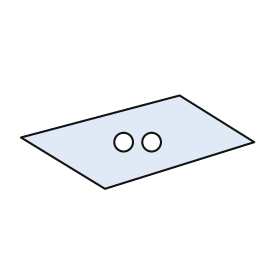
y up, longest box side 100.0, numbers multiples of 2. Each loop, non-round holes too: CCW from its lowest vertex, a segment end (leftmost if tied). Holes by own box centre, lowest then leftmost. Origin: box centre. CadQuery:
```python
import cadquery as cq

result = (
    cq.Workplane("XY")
    .moveTo(-14.0, -20.0)
    .lineTo(50.0, 0.0)
    .lineTo(18.0, 20.0)
    .lineTo(-50.0, 2.0)
    .close()
    .moveTo(-6.0, 0.0)
    .circle(4.0)
    .moveTo(6.0, 0.0)
    .circle(4.0)
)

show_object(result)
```